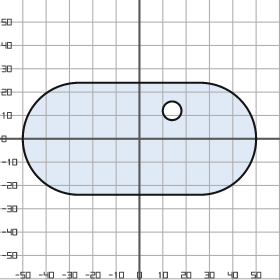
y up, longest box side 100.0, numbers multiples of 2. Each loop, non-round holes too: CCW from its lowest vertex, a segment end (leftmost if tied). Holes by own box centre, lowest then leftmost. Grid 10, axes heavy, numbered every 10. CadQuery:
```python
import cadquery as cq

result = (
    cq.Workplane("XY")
    .moveTo(-26.0, -24.0)
    .lineTo(26.0, -24.0)
    .threePointArc((50.0, 0.0), (26.0, 24.0))
    .lineTo(-26.0, 24.0)
    .threePointArc((-50.0, 0.0), (-26.0, -24.0))
    .close()
    .moveTo(14.0, 12.0)
    .circle(4.0)
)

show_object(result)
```